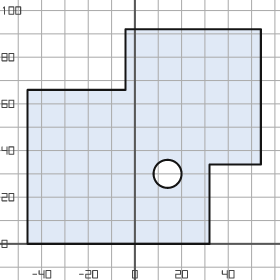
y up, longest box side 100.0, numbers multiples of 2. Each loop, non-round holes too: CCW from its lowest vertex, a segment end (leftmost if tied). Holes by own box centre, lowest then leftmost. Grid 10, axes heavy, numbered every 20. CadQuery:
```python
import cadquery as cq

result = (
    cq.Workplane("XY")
    .moveTo(-46.0, 0.0)
    .lineTo(32.0, 0.0)
    .lineTo(32.0, 34.0)
    .lineTo(54.0, 34.0)
    .lineTo(54.0, 92.0)
    .lineTo(-4.0, 92.0)
    .lineTo(-4.0, 66.0)
    .lineTo(-46.0, 66.0)
    .close()
    .moveTo(14.0, 30.0)
    .circle(6.0)
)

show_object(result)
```